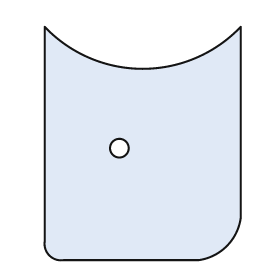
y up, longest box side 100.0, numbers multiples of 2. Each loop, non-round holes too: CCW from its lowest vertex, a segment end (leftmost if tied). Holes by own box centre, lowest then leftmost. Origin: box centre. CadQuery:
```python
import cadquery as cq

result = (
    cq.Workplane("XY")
    .moveTo(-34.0, -50.0)
    .lineTo(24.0, -50.0)
    .threePointArc((36.0, -44.0), (42.0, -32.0))
    .lineTo(42.0, 50.0)
    .threePointArc((0.0, 32.0), (-42.0, 50.0))
    .lineTo(-42.0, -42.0)
    .threePointArc((-40.0, -48.0), (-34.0, -50.0))
    .close()
    .moveTo(-10.0, -2.0)
    .circle(4.0)
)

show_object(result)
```